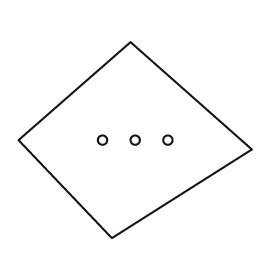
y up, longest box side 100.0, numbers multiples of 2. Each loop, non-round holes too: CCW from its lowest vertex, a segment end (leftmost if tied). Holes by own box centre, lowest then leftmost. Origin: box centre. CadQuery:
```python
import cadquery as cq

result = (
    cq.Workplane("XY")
    .moveTo(-10.0, -42.0)
    .lineTo(50.0, -4.0)
    .lineTo(-2.0, 42.0)
    .lineTo(-50.0, 0.0)
    .close()
    .moveTo(-14.0, 0.0)
    .circle(2.0)
    .moveTo(0.0, 0.0)
    .circle(2.0)
    .moveTo(14.0, 0.0)
    .circle(2.0)
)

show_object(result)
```